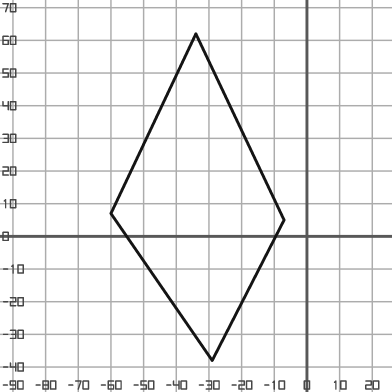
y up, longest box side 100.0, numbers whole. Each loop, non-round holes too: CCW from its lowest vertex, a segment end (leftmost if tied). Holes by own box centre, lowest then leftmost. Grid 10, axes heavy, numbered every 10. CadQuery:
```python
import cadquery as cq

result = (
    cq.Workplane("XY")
    .moveTo(-29.0, -38.0)
    .lineTo(-7.0, 5.0)
    .lineTo(-34.0, 62.0)
    .lineTo(-60.0, 7.0)
    .close()
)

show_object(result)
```